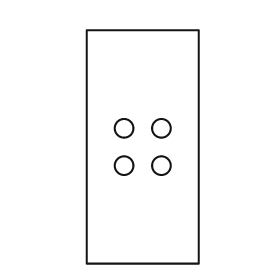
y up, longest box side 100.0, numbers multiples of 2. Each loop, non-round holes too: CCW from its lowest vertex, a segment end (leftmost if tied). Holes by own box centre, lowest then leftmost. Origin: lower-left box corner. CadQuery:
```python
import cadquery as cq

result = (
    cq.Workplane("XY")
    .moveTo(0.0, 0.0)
    .lineTo(48.0, 0.0)
    .lineTo(48.0, 100.0)
    .lineTo(0.0, 100.0)
    .close()
    .moveTo(16.0, 42.0)
    .circle(4.0)
    .moveTo(32.0, 42.0)
    .circle(4.0)
    .moveTo(16.0, 58.0)
    .circle(4.0)
    .moveTo(32.0, 58.0)
    .circle(4.0)
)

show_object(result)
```